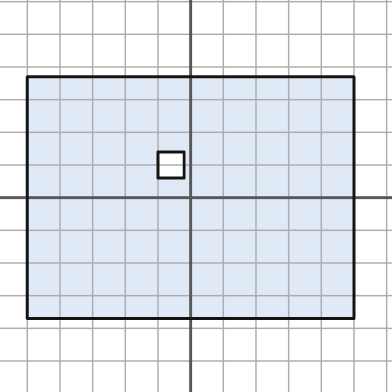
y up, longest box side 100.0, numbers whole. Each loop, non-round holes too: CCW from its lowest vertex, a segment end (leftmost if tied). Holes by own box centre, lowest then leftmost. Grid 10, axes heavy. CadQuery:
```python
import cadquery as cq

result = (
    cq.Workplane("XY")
    .moveTo(-50.0, -37.0)
    .lineTo(50.0, -37.0)
    .lineTo(50.0, 37.0)
    .lineTo(-50.0, 37.0)
    .close()
    .moveTo(-10.0, 6.0)
    .lineTo(-2.0, 6.0)
    .lineTo(-2.0, 14.0)
    .lineTo(-10.0, 14.0)
    .close()
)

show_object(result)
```